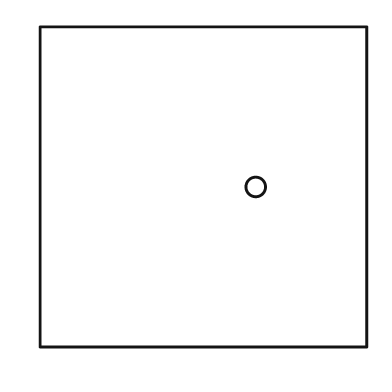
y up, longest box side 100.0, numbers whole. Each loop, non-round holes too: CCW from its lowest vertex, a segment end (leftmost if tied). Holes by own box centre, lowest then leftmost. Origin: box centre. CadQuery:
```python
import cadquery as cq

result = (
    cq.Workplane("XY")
    .moveTo(-50.0, -49.0)
    .lineTo(50.0, -49.0)
    .lineTo(50.0, 49.0)
    .lineTo(-50.0, 49.0)
    .close()
    .moveTo(16.0, 0.0)
    .circle(3.0)
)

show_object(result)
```